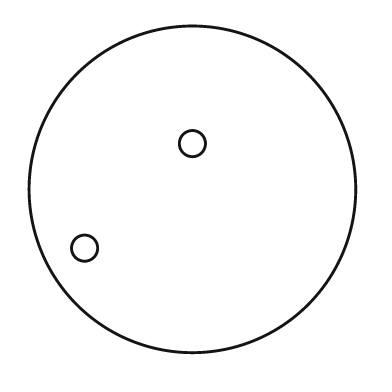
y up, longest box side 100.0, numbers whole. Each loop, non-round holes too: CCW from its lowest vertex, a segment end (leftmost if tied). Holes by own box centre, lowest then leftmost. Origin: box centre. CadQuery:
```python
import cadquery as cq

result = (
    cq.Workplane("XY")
    .moveTo(0.0, 0.0)
    .circle(50.0)
    .moveTo(-33.0, -18.0)
    .circle(4.0)
    .moveTo(0.0, 14.0)
    .circle(4.0)
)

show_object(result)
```